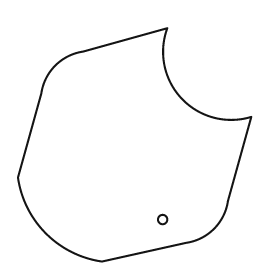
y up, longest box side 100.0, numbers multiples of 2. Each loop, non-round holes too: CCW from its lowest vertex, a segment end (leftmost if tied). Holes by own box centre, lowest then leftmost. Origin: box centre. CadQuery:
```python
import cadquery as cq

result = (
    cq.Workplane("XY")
    .moveTo(-14.0, -50.0)
    .lineTo(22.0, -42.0)
    .threePointArc((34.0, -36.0), (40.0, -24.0))
    .lineTo(50.0, 12.0)
    .threePointArc((20.0, 20.0), (14.0, 50.0))
    .lineTo(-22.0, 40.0)
    .threePointArc((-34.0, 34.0), (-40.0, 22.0))
    .lineTo(-50.0, -14.0)
    .threePointArc((-38.0, -38.0), (-14.0, -50.0))
    .close()
    .moveTo(12.0, -32.0)
    .circle(2.0)
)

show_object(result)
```